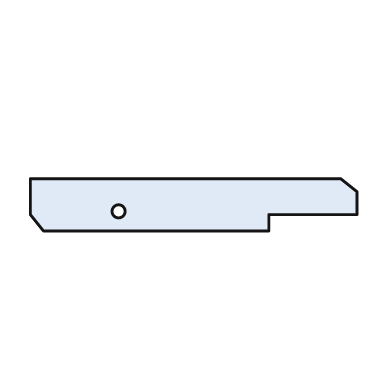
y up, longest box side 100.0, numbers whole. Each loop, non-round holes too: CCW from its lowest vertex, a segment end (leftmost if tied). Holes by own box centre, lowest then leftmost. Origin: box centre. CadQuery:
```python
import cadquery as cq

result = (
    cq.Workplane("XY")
    .moveTo(-46.0, -8.0)
    .lineTo(23.0, -8.0)
    .lineTo(23.0, -3.0)
    .lineTo(50.0, -3.0)
    .lineTo(50.0, 4.0)
    .lineTo(45.0, 8.0)
    .lineTo(-50.0, 8.0)
    .lineTo(-50.0, -3.0)
    .close()
    .moveTo(-23.0, -2.0)
    .circle(2.0)
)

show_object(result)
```